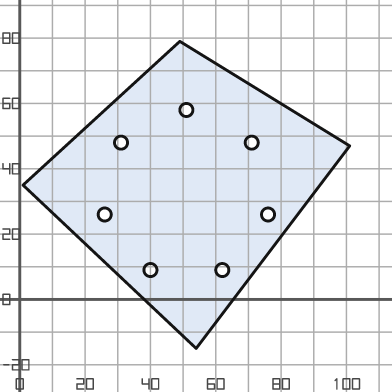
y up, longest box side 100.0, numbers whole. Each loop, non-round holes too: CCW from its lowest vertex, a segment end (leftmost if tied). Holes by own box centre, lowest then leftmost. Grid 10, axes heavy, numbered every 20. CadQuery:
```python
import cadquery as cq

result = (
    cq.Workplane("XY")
    .moveTo(54.0, -15.0)
    .lineTo(101.0, 47.0)
    .lineTo(49.0, 79.0)
    .lineTo(1.0, 35.0)
    .close()
    .moveTo(40.0, 9.0)
    .circle(2.0)
    .moveTo(62.0, 9.0)
    .circle(2.0)
    .moveTo(26.0, 26.0)
    .circle(2.0)
    .moveTo(76.0, 26.0)
    .circle(2.0)
    .moveTo(31.0, 48.0)
    .circle(2.0)
    .moveTo(71.0, 48.0)
    .circle(2.0)
    .moveTo(51.0, 58.0)
    .circle(2.0)
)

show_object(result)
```